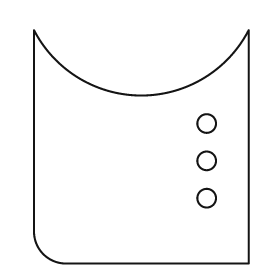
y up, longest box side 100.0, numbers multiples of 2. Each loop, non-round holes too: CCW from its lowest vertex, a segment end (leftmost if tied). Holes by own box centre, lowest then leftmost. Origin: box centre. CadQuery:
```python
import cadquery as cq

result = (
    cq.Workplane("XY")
    .moveTo(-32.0, -50.0)
    .lineTo(46.0, -50.0)
    .lineTo(46.0, 50.0)
    .threePointArc((0.0, 22.0), (-46.0, 50.0))
    .lineTo(-46.0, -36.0)
    .threePointArc((-42.0, -46.0), (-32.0, -50.0))
    .close()
    .moveTo(28.0, -22.0)
    .circle(4.0)
    .moveTo(28.0, -6.0)
    .circle(4.0)
    .moveTo(28.0, 10.0)
    .circle(4.0)
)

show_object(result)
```